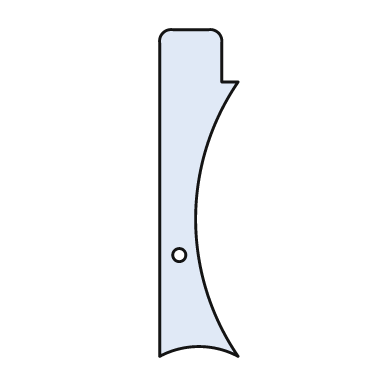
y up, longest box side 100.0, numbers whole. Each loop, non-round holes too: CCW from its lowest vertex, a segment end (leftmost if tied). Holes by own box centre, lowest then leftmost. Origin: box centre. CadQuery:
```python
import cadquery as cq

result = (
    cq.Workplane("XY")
    .moveTo(-12.0, -50.0)
    .threePointArc((0.0, -47.0), (12.0, -50.0))
    .threePointArc((-1.0, -8.0), (12.0, 34.0))
    .lineTo(7.0, 34.0)
    .lineTo(7.0, 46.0)
    .threePointArc((6.0, 49.0), (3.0, 50.0))
    .lineTo(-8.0, 50.0)
    .threePointArc((-11.0, 49.0), (-12.0, 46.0))
    .close()
    .moveTo(-6.0, -19.0)
    .circle(2.0)
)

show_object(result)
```